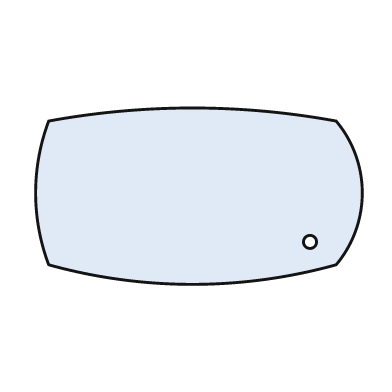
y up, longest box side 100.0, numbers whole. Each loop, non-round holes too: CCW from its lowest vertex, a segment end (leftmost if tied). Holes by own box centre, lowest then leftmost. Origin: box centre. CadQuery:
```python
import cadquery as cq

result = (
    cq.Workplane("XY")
    .moveTo(-46.0, -21.0)
    .threePointArc((-2.0, -27.0), (42.0, -21.0))
    .threePointArc((50.0, 1.0), (42.0, 23.0))
    .threePointArc((-2.0, 27.0), (-46.0, 23.0))
    .threePointArc((-50.0, 1.0), (-46.0, -21.0))
    .close()
    .moveTo(34.0, -14.0)
    .circle(2.0)
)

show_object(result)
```